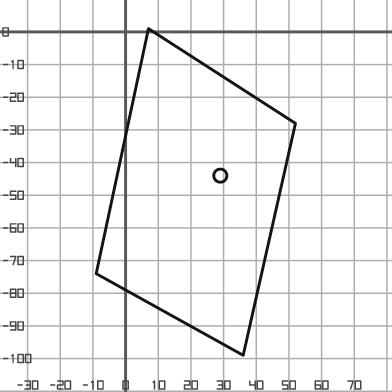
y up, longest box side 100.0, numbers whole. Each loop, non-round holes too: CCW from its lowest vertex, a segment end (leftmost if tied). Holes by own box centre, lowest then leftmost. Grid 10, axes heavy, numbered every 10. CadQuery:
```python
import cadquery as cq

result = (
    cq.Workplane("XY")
    .moveTo(36.0, -99.0)
    .lineTo(52.0, -28.0)
    .lineTo(7.0, 1.0)
    .lineTo(-9.0, -74.0)
    .close()
    .moveTo(29.0, -44.0)
    .circle(2.0)
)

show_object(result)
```